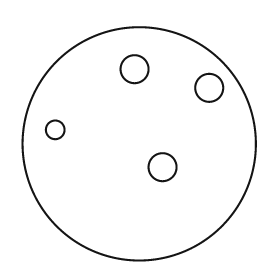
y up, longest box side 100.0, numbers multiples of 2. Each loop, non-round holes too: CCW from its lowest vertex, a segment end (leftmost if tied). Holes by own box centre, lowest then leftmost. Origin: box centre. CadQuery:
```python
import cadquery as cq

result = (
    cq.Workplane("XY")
    .moveTo(0.0, 0.0)
    .circle(50.0)
    .moveTo(10.0, -10.0)
    .circle(6.0)
    .moveTo(-36.0, 6.0)
    .circle(4.0)
    .moveTo(30.0, 24.0)
    .circle(6.0)
    .moveTo(-2.0, 32.0)
    .circle(6.0)
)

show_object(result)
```